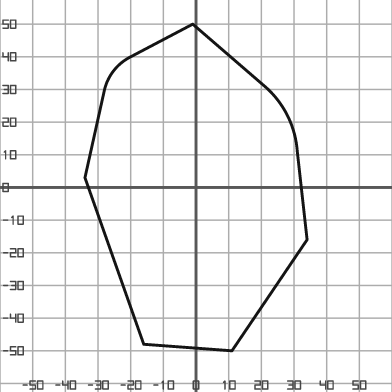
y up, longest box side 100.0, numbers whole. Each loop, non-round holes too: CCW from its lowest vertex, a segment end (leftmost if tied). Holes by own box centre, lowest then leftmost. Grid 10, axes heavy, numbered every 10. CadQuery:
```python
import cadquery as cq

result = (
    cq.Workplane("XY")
    .moveTo(11.0, -50.0)
    .lineTo(34.0, -16.0)
    .lineTo(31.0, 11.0)
    .threePointArc((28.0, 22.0), (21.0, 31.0))
    .lineTo(-1.0, 50.0)
    .lineTo(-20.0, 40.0)
    .threePointArc((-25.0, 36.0), (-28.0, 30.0))
    .lineTo(-34.0, 3.0)
    .lineTo(-16.0, -48.0)
    .close()
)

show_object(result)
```